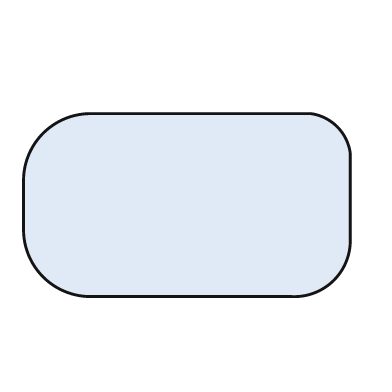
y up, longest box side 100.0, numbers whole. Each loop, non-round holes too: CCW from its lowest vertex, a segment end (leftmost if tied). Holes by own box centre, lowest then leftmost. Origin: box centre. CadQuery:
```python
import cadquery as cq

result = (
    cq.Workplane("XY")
    .moveTo(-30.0, -28.0)
    .lineTo(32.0, -28.0)
    .threePointArc((45.0, -23.0), (50.0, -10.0))
    .lineTo(50.0, 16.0)
    .threePointArc((46.0, 24.0), (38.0, 28.0))
    .lineTo(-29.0, 28.0)
    .threePointArc((-44.0, 22.0), (-50.0, 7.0))
    .lineTo(-50.0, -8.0)
    .threePointArc((-44.0, -22.0), (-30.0, -28.0))
    .close()
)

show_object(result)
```